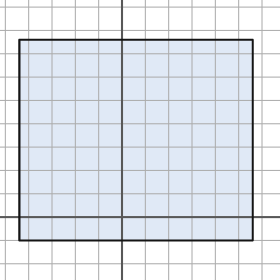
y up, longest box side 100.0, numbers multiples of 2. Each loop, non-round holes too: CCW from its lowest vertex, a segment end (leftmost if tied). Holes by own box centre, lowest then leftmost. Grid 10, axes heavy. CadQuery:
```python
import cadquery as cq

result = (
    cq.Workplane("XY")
    .moveTo(-44.0, -10.0)
    .lineTo(56.0, -10.0)
    .lineTo(56.0, 76.0)
    .lineTo(-44.0, 76.0)
    .close()
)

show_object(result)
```